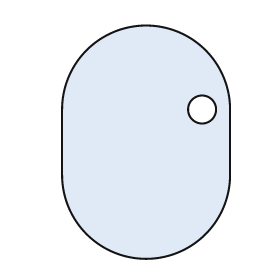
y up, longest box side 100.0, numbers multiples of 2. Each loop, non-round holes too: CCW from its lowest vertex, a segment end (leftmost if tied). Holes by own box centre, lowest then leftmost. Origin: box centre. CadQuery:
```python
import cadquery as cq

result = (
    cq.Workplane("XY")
    .moveTo(-36.0, -14.0)
    .threePointArc((0.0, -50.0), (36.0, -14.0))
    .lineTo(36.0, 14.0)
    .threePointArc((0.0, 50.0), (-36.0, 14.0))
    .close()
    .moveTo(24.0, 14.0)
    .circle(6.0)
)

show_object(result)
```